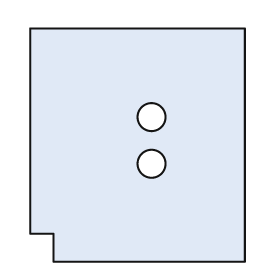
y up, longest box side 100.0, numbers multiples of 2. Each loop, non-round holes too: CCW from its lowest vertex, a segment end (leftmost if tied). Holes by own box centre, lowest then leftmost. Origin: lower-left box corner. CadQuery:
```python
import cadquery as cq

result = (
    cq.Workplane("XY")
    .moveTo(10.0, 0.0)
    .lineTo(92.0, 0.0)
    .lineTo(92.0, 100.0)
    .lineTo(0.0, 100.0)
    .lineTo(0.0, 12.0)
    .lineTo(10.0, 12.0)
    .close()
    .moveTo(52.0, 42.0)
    .circle(6.0)
    .moveTo(52.0, 62.0)
    .circle(6.0)
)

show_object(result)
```